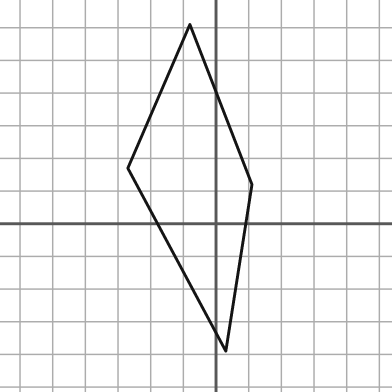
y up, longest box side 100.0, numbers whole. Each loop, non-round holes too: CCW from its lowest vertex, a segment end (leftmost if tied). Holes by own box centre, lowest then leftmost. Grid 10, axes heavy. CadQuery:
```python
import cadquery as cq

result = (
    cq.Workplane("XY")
    .moveTo(3.0, -39.0)
    .lineTo(11.0, 12.0)
    .lineTo(-8.0, 61.0)
    .lineTo(-27.0, 17.0)
    .close()
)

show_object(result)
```